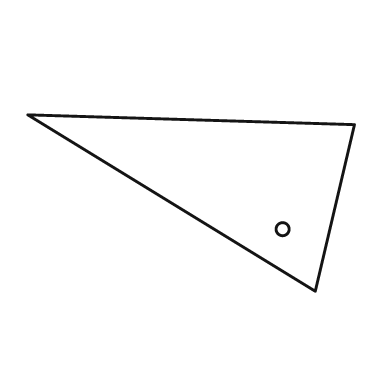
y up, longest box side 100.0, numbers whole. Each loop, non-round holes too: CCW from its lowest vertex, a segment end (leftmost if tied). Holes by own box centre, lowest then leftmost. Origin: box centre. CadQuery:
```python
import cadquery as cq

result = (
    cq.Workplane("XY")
    .moveTo(38.0, -27.0)
    .lineTo(50.0, 24.0)
    .lineTo(-50.0, 27.0)
    .close()
    .moveTo(28.0, -8.0)
    .circle(2.0)
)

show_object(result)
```